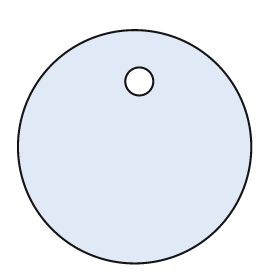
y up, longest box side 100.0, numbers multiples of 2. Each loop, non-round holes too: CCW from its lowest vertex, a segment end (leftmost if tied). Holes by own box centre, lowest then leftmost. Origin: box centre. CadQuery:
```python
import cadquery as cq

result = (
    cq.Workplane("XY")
    .moveTo(0.0, 0.0)
    .circle(50.0)
    .moveTo(2.0, 28.0)
    .circle(6.0)
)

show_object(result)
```